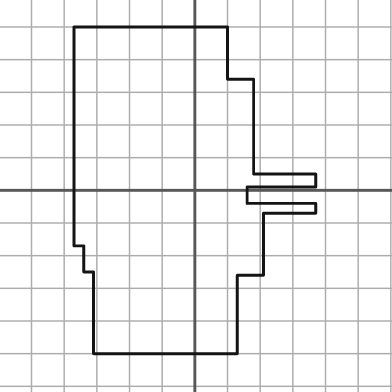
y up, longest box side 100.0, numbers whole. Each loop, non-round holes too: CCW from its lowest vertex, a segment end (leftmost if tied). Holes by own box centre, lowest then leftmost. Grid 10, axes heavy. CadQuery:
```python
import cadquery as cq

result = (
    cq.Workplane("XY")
    .moveTo(-31.0, -50.0)
    .lineTo(13.0, -50.0)
    .lineTo(13.0, -26.0)
    .lineTo(21.0, -26.0)
    .lineTo(21.0, -7.0)
    .lineTo(37.0, -7.0)
    .lineTo(37.0, -4.0)
    .lineTo(16.0, -4.0)
    .lineTo(16.0, 1.0)
    .lineTo(37.0, 1.0)
    .lineTo(37.0, 5.0)
    .lineTo(18.0, 5.0)
    .lineTo(18.0, 34.0)
    .lineTo(10.0, 34.0)
    .lineTo(10.0, 50.0)
    .lineTo(-37.0, 50.0)
    .lineTo(-37.0, -17.0)
    .lineTo(-34.0, -17.0)
    .lineTo(-34.0, -25.0)
    .lineTo(-31.0, -25.0)
    .close()
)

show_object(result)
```